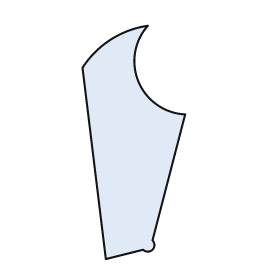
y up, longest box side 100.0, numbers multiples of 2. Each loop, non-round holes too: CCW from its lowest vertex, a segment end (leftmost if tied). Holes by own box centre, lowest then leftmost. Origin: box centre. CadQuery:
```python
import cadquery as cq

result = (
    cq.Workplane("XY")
    .moveTo(-12.0, -50.0)
    .lineTo(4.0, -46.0)
    .threePointArc((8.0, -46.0), (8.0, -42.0))
    .lineTo(22.0, 12.0)
    .threePointArc((2.0, 26.0), (6.0, 50.0))
    .threePointArc((-10.0, 44.0), (-22.0, 32.0))
    .close()
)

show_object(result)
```